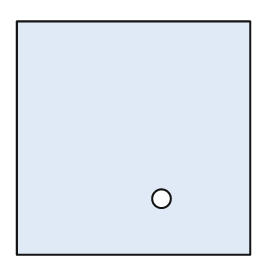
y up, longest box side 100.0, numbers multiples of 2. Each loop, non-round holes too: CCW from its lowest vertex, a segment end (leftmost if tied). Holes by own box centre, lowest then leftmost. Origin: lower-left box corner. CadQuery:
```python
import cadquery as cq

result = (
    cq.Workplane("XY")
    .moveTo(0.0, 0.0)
    .lineTo(100.0, 0.0)
    .lineTo(100.0, 100.0)
    .lineTo(0.0, 100.0)
    .close()
    .moveTo(62.0, 24.0)
    .circle(4.0)
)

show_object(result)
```